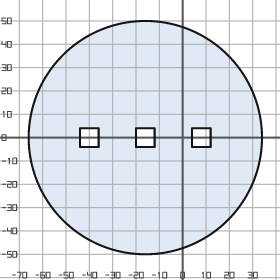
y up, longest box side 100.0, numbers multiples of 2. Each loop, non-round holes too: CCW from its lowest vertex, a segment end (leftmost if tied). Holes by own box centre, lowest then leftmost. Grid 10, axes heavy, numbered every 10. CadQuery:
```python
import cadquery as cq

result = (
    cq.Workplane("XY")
    .moveTo(-16.0, 0.0)
    .circle(50.0)
    .moveTo(-44.0, -4.0)
    .lineTo(-36.0, -4.0)
    .lineTo(-36.0, 4.0)
    .lineTo(-44.0, 4.0)
    .close()
    .moveTo(-20.0, -4.0)
    .lineTo(-12.0, -4.0)
    .lineTo(-12.0, 4.0)
    .lineTo(-20.0, 4.0)
    .close()
    .moveTo(4.0, -4.0)
    .lineTo(12.0, -4.0)
    .lineTo(12.0, 4.0)
    .lineTo(4.0, 4.0)
    .close()
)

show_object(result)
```